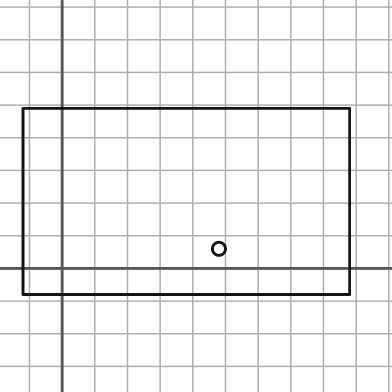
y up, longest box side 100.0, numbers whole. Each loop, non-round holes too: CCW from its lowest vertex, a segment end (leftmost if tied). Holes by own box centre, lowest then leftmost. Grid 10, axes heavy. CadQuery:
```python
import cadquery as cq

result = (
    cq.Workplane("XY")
    .moveTo(-12.0, -8.0)
    .lineTo(88.0, -8.0)
    .lineTo(88.0, 49.0)
    .lineTo(-12.0, 49.0)
    .close()
    .moveTo(48.0, 6.0)
    .circle(2.0)
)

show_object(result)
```